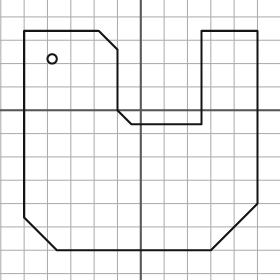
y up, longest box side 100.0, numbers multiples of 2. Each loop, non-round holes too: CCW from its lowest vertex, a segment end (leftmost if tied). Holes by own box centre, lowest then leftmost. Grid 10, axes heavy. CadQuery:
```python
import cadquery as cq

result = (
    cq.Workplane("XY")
    .moveTo(-36.0, -60.0)
    .lineTo(30.0, -60.0)
    .lineTo(50.0, -40.0)
    .lineTo(50.0, 34.0)
    .lineTo(26.0, 34.0)
    .lineTo(26.0, -6.0)
    .lineTo(-4.0, -6.0)
    .lineTo(-10.0, 0.0)
    .lineTo(-10.0, 26.0)
    .lineTo(-18.0, 34.0)
    .lineTo(-50.0, 34.0)
    .lineTo(-50.0, -46.0)
    .close()
    .moveTo(-38.0, 22.0)
    .circle(2.0)
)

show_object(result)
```